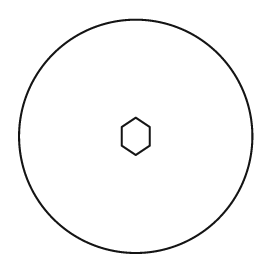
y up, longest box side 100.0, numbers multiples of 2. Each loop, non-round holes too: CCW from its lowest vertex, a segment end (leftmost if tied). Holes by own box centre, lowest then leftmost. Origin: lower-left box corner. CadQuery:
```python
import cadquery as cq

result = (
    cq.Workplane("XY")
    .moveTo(50.0, 50.0)
    .circle(50.0)
    .moveTo(50.0, 42.0)
    .lineTo(56.0, 46.0)
    .lineTo(56.0, 54.0)
    .lineTo(50.0, 58.0)
    .lineTo(44.0, 54.0)
    .lineTo(44.0, 46.0)
    .close()
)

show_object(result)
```